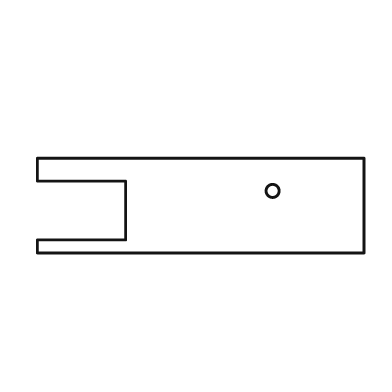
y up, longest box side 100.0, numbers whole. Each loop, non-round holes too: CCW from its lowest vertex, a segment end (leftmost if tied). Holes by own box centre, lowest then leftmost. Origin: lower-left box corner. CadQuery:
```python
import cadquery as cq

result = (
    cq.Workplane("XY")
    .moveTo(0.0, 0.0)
    .lineTo(100.0, 0.0)
    .lineTo(100.0, 29.0)
    .lineTo(0.0, 29.0)
    .lineTo(0.0, 22.0)
    .lineTo(27.0, 22.0)
    .lineTo(27.0, 4.0)
    .lineTo(0.0, 4.0)
    .close()
    .moveTo(72.0, 19.0)
    .circle(2.0)
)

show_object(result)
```